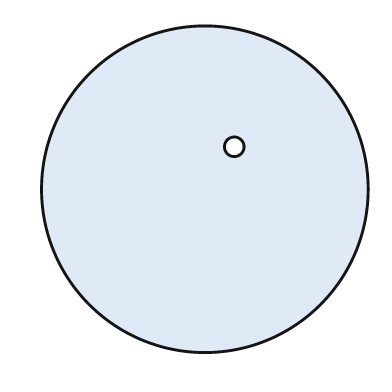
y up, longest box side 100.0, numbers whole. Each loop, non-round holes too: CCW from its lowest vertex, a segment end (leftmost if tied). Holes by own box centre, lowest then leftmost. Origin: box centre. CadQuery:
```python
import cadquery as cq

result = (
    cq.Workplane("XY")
    .moveTo(0.0, 0.0)
    .circle(50.0)
    .moveTo(9.0, 13.0)
    .circle(3.0)
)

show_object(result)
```